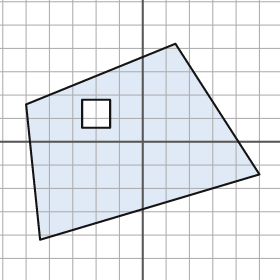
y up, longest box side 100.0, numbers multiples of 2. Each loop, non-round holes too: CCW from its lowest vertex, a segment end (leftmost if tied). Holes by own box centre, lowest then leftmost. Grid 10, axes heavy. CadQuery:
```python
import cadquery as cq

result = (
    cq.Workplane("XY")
    .moveTo(-44.0, -42.0)
    .lineTo(50.0, -14.0)
    .lineTo(14.0, 42.0)
    .lineTo(-50.0, 16.0)
    .close()
    .moveTo(-26.0, 6.0)
    .lineTo(-14.0, 6.0)
    .lineTo(-14.0, 18.0)
    .lineTo(-26.0, 18.0)
    .close()
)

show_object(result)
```